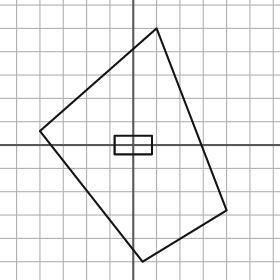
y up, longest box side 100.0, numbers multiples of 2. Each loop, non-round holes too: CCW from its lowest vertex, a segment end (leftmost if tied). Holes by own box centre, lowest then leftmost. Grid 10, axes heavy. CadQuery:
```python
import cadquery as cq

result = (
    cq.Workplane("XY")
    .moveTo(4.0, -50.0)
    .lineTo(40.0, -28.0)
    .lineTo(10.0, 50.0)
    .lineTo(-40.0, 6.0)
    .close()
    .moveTo(-8.0, -4.0)
    .lineTo(8.0, -4.0)
    .lineTo(8.0, 4.0)
    .lineTo(-8.0, 4.0)
    .close()
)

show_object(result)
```